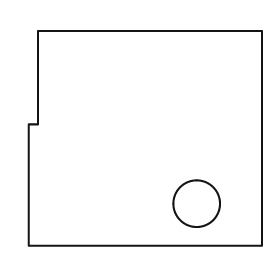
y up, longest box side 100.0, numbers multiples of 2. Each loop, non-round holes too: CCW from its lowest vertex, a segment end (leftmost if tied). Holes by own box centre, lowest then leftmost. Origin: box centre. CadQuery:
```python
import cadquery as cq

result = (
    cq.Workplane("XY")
    .moveTo(-50.0, -46.0)
    .lineTo(50.0, -46.0)
    .lineTo(50.0, 46.0)
    .lineTo(-46.0, 46.0)
    .lineTo(-46.0, 6.0)
    .lineTo(-50.0, 6.0)
    .close()
    .moveTo(22.0, -28.0)
    .circle(10.0)
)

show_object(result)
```